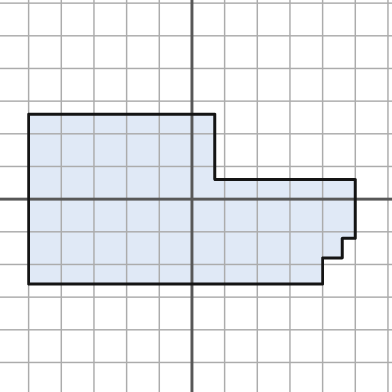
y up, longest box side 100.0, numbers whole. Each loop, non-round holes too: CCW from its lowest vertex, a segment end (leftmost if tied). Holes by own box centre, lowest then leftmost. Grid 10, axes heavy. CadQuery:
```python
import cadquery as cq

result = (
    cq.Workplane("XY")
    .moveTo(-50.0, -26.0)
    .lineTo(40.0, -26.0)
    .lineTo(40.0, -18.0)
    .lineTo(46.0, -18.0)
    .lineTo(46.0, -12.0)
    .lineTo(50.0, -12.0)
    .lineTo(50.0, 6.0)
    .lineTo(7.0, 6.0)
    .lineTo(7.0, 26.0)
    .lineTo(-50.0, 26.0)
    .close()
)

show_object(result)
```